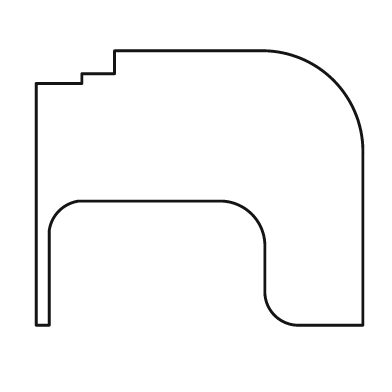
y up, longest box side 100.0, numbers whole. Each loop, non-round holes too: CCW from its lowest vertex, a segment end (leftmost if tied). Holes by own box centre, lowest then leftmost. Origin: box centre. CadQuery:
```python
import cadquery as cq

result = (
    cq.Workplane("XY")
    .moveTo(-50.0, -42.0)
    .lineTo(-46.0, -42.0)
    .lineTo(-46.0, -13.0)
    .threePointArc((-43.0, -7.0), (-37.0, -4.0))
    .lineTo(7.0, -4.0)
    .threePointArc((16.0, -8.0), (20.0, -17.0))
    .lineTo(20.0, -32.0)
    .threePointArc((23.0, -39.0), (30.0, -42.0))
    .lineTo(50.0, -42.0)
    .lineTo(50.0, 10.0)
    .threePointArc((41.0, 33.0), (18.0, 42.0))
    .lineTo(-26.0, 42.0)
    .lineTo(-26.0, 35.0)
    .lineTo(-36.0, 35.0)
    .lineTo(-36.0, 32.0)
    .lineTo(-50.0, 32.0)
    .close()
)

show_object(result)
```